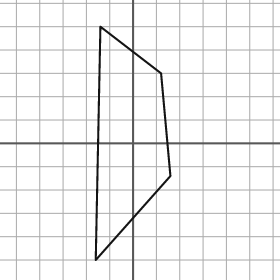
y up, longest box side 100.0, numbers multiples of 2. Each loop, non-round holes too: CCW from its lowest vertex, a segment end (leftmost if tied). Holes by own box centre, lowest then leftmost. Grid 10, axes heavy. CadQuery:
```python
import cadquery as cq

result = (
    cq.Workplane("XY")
    .moveTo(-16.0, -50.0)
    .lineTo(16.0, -14.0)
    .lineTo(12.0, 30.0)
    .lineTo(-14.0, 50.0)
    .close()
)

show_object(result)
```